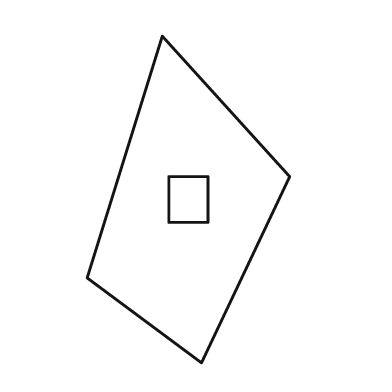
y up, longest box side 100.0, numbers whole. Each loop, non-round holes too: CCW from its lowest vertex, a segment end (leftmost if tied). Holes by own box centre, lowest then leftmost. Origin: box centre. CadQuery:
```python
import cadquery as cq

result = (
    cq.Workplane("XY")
    .moveTo(4.0, -50.0)
    .lineTo(31.0, 7.0)
    .lineTo(-8.0, 50.0)
    .lineTo(-31.0, -24.0)
    .close()
    .moveTo(-6.0, -7.0)
    .lineTo(6.0, -7.0)
    .lineTo(6.0, 7.0)
    .lineTo(-6.0, 7.0)
    .close()
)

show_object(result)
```